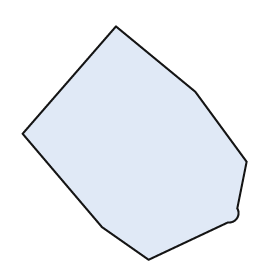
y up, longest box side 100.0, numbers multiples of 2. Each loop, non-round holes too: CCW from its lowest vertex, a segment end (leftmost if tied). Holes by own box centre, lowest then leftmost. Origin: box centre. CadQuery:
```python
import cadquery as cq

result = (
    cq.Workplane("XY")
    .moveTo(6.0, -50.0)
    .lineTo(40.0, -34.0)
    .threePointArc((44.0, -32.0), (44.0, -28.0))
    .lineTo(48.0, -8.0)
    .lineTo(26.0, 22.0)
    .lineTo(-8.0, 50.0)
    .lineTo(-48.0, 4.0)
    .lineTo(-14.0, -36.0)
    .close()
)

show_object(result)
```